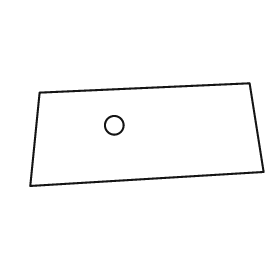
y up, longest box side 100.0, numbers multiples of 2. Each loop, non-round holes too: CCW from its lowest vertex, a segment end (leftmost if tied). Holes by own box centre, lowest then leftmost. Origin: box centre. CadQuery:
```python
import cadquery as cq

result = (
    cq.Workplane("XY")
    .moveTo(-50.0, -22.0)
    .lineTo(50.0, -16.0)
    .lineTo(44.0, 22.0)
    .lineTo(-46.0, 18.0)
    .close()
    .moveTo(-14.0, 4.0)
    .circle(4.0)
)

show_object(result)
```